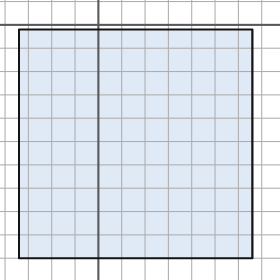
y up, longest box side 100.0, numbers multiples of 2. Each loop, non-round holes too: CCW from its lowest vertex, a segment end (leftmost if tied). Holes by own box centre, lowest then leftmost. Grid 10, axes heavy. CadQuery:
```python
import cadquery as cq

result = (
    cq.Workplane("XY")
    .moveTo(-34.0, -100.0)
    .lineTo(66.0, -100.0)
    .lineTo(66.0, -2.0)
    .lineTo(-34.0, -2.0)
    .close()
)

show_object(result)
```